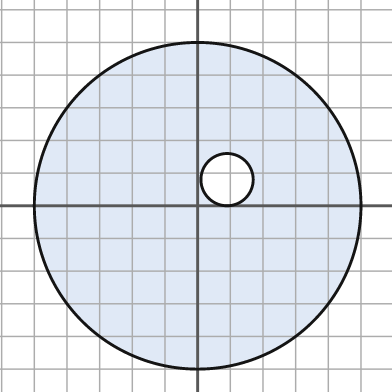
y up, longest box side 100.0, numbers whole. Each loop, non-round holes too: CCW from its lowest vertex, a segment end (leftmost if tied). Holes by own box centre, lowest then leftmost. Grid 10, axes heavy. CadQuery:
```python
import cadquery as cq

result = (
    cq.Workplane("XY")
    .moveTo(0.0, 0.0)
    .circle(50.0)
    .moveTo(9.0, 8.0)
    .circle(8.0)
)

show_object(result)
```